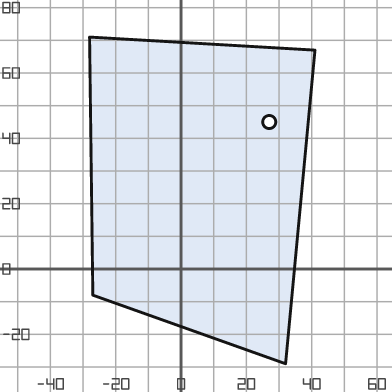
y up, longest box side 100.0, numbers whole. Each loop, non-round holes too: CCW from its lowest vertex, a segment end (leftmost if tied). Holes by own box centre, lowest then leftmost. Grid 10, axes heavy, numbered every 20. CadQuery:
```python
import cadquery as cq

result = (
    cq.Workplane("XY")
    .moveTo(32.0, -29.0)
    .lineTo(41.0, 67.0)
    .lineTo(-28.0, 71.0)
    .lineTo(-27.0, -8.0)
    .close()
    .moveTo(27.0, 45.0)
    .circle(2.0)
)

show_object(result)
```